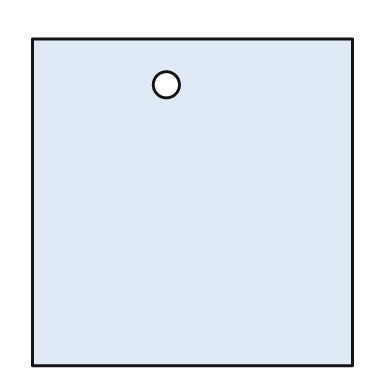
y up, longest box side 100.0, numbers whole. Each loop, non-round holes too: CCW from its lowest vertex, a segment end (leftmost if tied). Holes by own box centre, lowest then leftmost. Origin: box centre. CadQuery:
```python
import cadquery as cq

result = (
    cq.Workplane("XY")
    .moveTo(-49.0, -50.0)
    .lineTo(49.0, -50.0)
    .lineTo(49.0, 50.0)
    .lineTo(-49.0, 50.0)
    .close()
    .moveTo(-8.0, 36.0)
    .circle(4.0)
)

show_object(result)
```